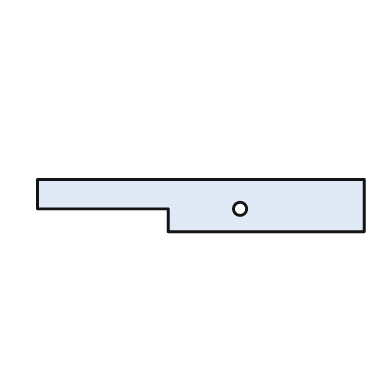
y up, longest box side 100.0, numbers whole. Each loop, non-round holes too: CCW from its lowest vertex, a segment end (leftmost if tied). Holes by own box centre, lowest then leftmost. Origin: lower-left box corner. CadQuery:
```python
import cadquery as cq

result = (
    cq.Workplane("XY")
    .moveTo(40.0, 0.0)
    .lineTo(100.0, 0.0)
    .lineTo(100.0, 16.0)
    .lineTo(0.0, 16.0)
    .lineTo(0.0, 7.0)
    .lineTo(40.0, 7.0)
    .close()
    .moveTo(62.0, 7.0)
    .circle(2.0)
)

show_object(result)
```